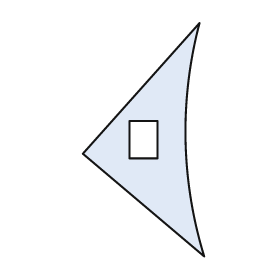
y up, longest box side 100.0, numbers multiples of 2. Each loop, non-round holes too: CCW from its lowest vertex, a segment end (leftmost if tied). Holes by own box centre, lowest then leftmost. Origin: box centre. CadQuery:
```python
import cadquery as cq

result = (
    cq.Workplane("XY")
    .moveTo(26.0, -50.0)
    .threePointArc((18.0, 0.0), (24.0, 50.0))
    .lineTo(-26.0, -6.0)
    .close()
    .moveTo(-6.0, -8.0)
    .lineTo(6.0, -8.0)
    .lineTo(6.0, 8.0)
    .lineTo(-6.0, 8.0)
    .close()
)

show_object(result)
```